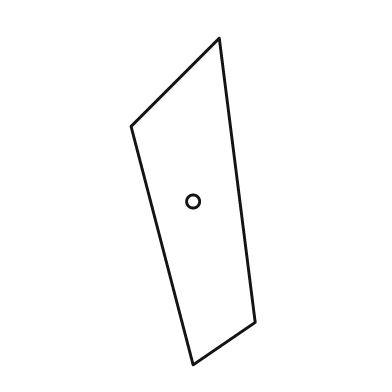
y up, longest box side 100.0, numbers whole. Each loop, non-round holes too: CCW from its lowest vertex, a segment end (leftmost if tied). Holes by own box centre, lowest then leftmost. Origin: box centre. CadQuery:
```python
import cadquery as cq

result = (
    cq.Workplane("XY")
    .moveTo(0.0, -50.0)
    .lineTo(19.0, -37.0)
    .lineTo(8.0, 50.0)
    .lineTo(-19.0, 23.0)
    .close()
    .moveTo(0.0, 0.0)
    .circle(2.0)
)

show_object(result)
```